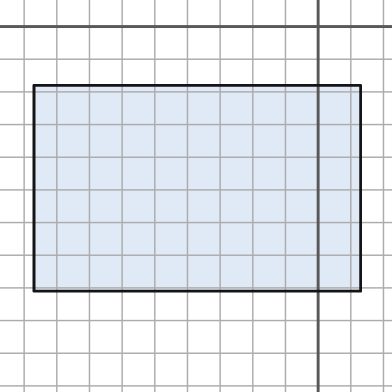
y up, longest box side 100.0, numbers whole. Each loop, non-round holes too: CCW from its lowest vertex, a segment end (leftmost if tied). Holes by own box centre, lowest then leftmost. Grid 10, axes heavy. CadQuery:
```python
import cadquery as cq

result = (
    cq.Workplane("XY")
    .moveTo(-87.0, -81.0)
    .lineTo(13.0, -81.0)
    .lineTo(13.0, -18.0)
    .lineTo(-87.0, -18.0)
    .close()
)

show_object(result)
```